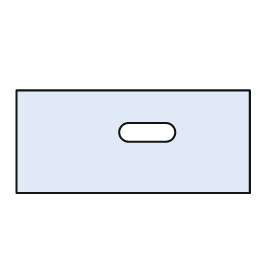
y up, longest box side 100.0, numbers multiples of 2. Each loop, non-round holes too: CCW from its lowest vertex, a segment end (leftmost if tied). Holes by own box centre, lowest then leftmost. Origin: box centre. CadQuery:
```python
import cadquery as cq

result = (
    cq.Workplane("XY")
    .moveTo(-50.0, -22.0)
    .lineTo(50.0, -22.0)
    .lineTo(50.0, 22.0)
    .lineTo(-50.0, 22.0)
    .close()
    .moveTo(-2.0, 0.0)
    .lineTo(14.0, 0.0)
    .threePointArc((18.0, 4.0), (14.0, 8.0))
    .lineTo(-2.0, 8.0)
    .threePointArc((-6.0, 4.0), (-2.0, 0.0))
    .close()
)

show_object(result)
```